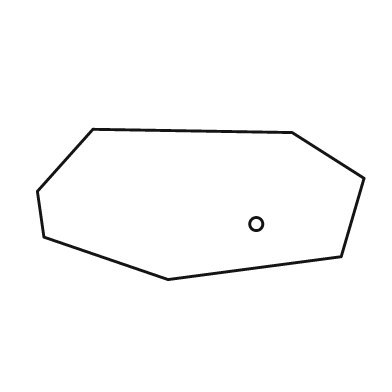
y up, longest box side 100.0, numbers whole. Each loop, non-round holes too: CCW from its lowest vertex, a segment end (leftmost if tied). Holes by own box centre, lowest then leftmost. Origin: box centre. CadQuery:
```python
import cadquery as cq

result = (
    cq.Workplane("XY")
    .moveTo(-10.0, -23.0)
    .lineTo(43.0, -16.0)
    .lineTo(50.0, 8.0)
    .lineTo(28.0, 22.0)
    .lineTo(-33.0, 23.0)
    .lineTo(-50.0, 4.0)
    .lineTo(-48.0, -10.0)
    .close()
    .moveTo(17.0, -6.0)
    .circle(2.0)
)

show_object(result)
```